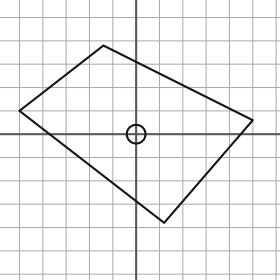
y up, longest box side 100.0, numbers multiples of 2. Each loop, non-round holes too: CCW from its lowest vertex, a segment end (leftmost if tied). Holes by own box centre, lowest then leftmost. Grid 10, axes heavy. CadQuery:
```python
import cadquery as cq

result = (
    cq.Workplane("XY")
    .moveTo(12.0, -38.0)
    .lineTo(50.0, 6.0)
    .lineTo(-14.0, 38.0)
    .lineTo(-50.0, 10.0)
    .close()
    .moveTo(0.0, 0.0)
    .circle(4.0)
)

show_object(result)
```